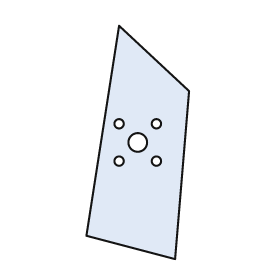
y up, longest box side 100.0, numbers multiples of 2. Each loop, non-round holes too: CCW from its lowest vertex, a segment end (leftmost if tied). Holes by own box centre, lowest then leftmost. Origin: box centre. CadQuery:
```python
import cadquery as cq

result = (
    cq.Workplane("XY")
    .moveTo(16.0, -50.0)
    .lineTo(22.0, 22.0)
    .lineTo(-8.0, 50.0)
    .lineTo(-22.0, -40.0)
    .close()
    .moveTo(-8.0, -8.0)
    .circle(2.0)
    .moveTo(8.0, -8.0)
    .circle(2.0)
    .moveTo(0.0, 0.0)
    .circle(4.0)
    .moveTo(-8.0, 8.0)
    .circle(2.0)
    .moveTo(8.0, 8.0)
    .circle(2.0)
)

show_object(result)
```